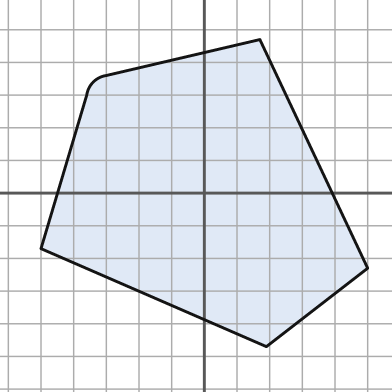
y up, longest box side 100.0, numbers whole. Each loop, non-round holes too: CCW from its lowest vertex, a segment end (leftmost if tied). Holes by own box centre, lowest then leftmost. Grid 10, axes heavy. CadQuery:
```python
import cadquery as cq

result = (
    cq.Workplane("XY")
    .moveTo(19.0, -47.0)
    .lineTo(50.0, -23.0)
    .lineTo(17.0, 47.0)
    .lineTo(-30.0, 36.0)
    .threePointArc((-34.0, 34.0), (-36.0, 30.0))
    .lineTo(-50.0, -17.0)
    .close()
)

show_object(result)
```